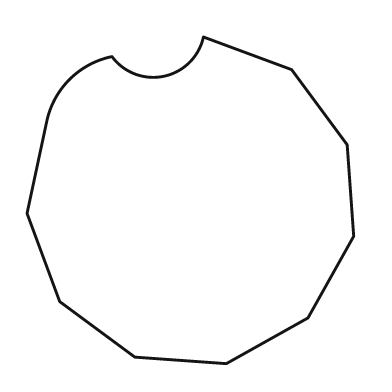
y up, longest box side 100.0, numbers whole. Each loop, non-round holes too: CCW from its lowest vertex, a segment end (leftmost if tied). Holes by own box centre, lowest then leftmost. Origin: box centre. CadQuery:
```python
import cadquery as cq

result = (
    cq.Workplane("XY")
    .moveTo(11.0, -50.0)
    .lineTo(36.0, -36.0)
    .lineTo(50.0, -11.0)
    .lineTo(48.0, 17.0)
    .lineTo(31.0, 40.0)
    .lineTo(4.0, 50.0)
    .threePointArc((-8.0, 38.0), (-24.0, 44.0))
    .threePointArc((-37.0, 37.0), (-44.0, 24.0))
    .lineTo(-50.0, -4.0)
    .lineTo(-40.0, -31.0)
    .lineTo(-17.0, -48.0)
    .close()
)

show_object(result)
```